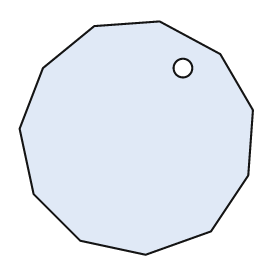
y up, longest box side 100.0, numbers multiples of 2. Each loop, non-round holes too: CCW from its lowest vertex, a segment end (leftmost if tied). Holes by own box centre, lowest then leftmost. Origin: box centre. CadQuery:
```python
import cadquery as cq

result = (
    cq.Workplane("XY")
    .moveTo(4.0, -50.0)
    .lineTo(32.0, -40.0)
    .lineTo(48.0, -16.0)
    .lineTo(50.0, 12.0)
    .lineTo(36.0, 36.0)
    .lineTo(10.0, 50.0)
    .lineTo(-18.0, 48.0)
    .lineTo(-40.0, 30.0)
    .lineTo(-50.0, 4.0)
    .lineTo(-44.0, -24.0)
    .lineTo(-24.0, -44.0)
    .close()
    .moveTo(20.0, 30.0)
    .circle(4.0)
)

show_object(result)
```